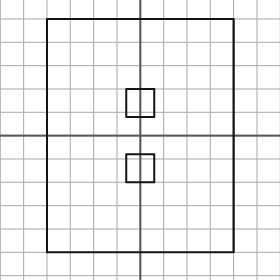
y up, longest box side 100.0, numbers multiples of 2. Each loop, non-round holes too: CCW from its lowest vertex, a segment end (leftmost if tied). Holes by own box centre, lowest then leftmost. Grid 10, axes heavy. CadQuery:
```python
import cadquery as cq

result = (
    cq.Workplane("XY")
    .moveTo(-40.0, -50.0)
    .lineTo(40.0, -50.0)
    .lineTo(40.0, 50.0)
    .lineTo(-40.0, 50.0)
    .close()
    .moveTo(-6.0, -20.0)
    .lineTo(6.0, -20.0)
    .lineTo(6.0, -8.0)
    .lineTo(-6.0, -8.0)
    .close()
    .moveTo(-6.0, 8.0)
    .lineTo(6.0, 8.0)
    .lineTo(6.0, 20.0)
    .lineTo(-6.0, 20.0)
    .close()
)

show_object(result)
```